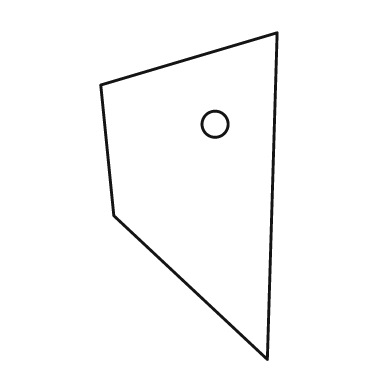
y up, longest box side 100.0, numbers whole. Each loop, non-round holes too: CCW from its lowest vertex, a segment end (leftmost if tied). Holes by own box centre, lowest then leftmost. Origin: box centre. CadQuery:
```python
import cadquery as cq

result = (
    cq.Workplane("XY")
    .moveTo(24.0, -50.0)
    .lineTo(27.0, 50.0)
    .lineTo(-27.0, 34.0)
    .lineTo(-23.0, -6.0)
    .close()
    .moveTo(8.0, 22.0)
    .circle(4.0)
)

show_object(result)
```